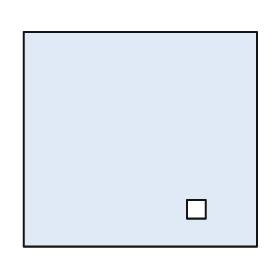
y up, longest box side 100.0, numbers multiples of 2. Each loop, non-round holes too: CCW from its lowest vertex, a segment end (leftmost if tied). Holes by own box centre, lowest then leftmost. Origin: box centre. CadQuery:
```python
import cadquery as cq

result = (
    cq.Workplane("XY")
    .moveTo(-50.0, -46.0)
    .lineTo(50.0, -46.0)
    .lineTo(50.0, 46.0)
    .lineTo(-50.0, 46.0)
    .close()
    .moveTo(20.0, -34.0)
    .lineTo(28.0, -34.0)
    .lineTo(28.0, -26.0)
    .lineTo(20.0, -26.0)
    .close()
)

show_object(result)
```